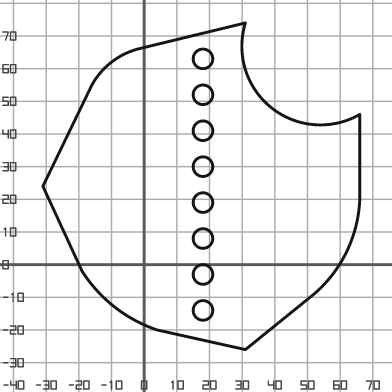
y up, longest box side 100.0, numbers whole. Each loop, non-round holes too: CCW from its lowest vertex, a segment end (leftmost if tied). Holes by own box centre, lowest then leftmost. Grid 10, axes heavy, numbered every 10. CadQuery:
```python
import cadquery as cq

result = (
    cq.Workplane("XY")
    .moveTo(31.0, -26.0)
    .lineTo(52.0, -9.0)
    .threePointArc((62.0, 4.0), (66.0, 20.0))
    .lineTo(66.0, 46.0)
    .threePointArc((39.0, 48.0), (31.0, 74.0))
    .lineTo(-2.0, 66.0)
    .threePointArc((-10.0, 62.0), (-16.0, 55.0))
    .lineTo(-31.0, 24.0)
    .lineTo(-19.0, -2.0)
    .threePointArc((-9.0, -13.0), (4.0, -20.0))
    .close()
    .moveTo(18.0, -14.0)
    .circle(3.0)
    .moveTo(18.0, -3.0)
    .circle(3.0)
    .moveTo(18.0, 8.0)
    .circle(3.0)
    .moveTo(18.0, 19.0)
    .circle(3.0)
    .moveTo(18.0, 30.0)
    .circle(3.0)
    .moveTo(18.0, 41.0)
    .circle(3.0)
    .moveTo(18.0, 52.0)
    .circle(3.0)
    .moveTo(18.0, 63.0)
    .circle(3.0)
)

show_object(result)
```